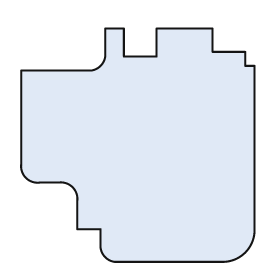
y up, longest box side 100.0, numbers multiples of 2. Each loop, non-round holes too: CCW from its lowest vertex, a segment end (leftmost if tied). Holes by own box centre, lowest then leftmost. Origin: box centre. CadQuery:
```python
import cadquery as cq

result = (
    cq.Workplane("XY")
    .moveTo(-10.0, -50.0)
    .lineTo(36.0, -50.0)
    .threePointArc((46.0, -46.0), (50.0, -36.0))
    .lineTo(50.0, 34.0)
    .lineTo(46.0, 34.0)
    .lineTo(46.0, 40.0)
    .lineTo(32.0, 40.0)
    .lineTo(32.0, 50.0)
    .lineTo(8.0, 50.0)
    .lineTo(8.0, 38.0)
    .lineTo(-6.0, 38.0)
    .lineTo(-6.0, 50.0)
    .lineTo(-14.0, 50.0)
    .lineTo(-14.0, 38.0)
    .threePointArc((-16.0, 34.0), (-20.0, 32.0))
    .lineTo(-50.0, 32.0)
    .lineTo(-50.0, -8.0)
    .threePointArc((-48.0, -14.0), (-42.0, -16.0))
    .lineTo(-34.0, -16.0)
    .threePointArc((-28.0, -18.0), (-26.0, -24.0))
    .lineTo(-26.0, -36.0)
    .lineTo(-16.0, -36.0)
    .lineTo(-16.0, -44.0)
    .threePointArc((-14.0, -48.0), (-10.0, -50.0))
    .close()
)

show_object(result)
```